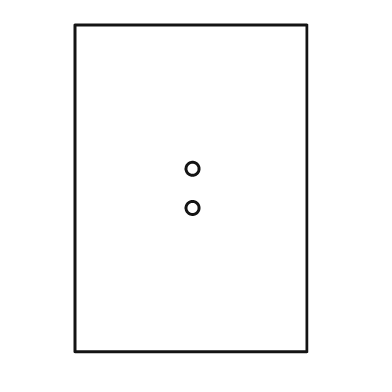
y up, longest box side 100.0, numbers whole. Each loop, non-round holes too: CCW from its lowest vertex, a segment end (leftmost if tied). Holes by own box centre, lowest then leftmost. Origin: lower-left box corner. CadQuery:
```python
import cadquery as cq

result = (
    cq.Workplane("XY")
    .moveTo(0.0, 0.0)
    .lineTo(71.0, 0.0)
    .lineTo(71.0, 100.0)
    .lineTo(0.0, 100.0)
    .close()
    .moveTo(36.0, 44.0)
    .circle(2.0)
    .moveTo(36.0, 56.0)
    .circle(2.0)
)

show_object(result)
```